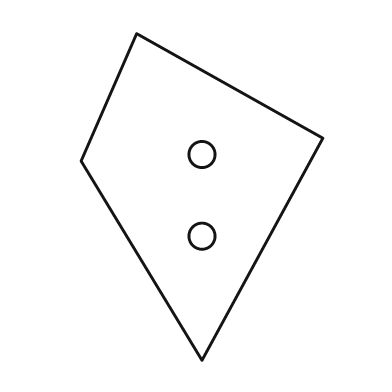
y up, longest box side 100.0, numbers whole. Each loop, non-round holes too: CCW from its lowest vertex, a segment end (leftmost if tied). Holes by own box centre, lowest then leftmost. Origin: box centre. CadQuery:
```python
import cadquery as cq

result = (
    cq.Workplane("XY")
    .moveTo(0.0, -50.0)
    .lineTo(37.0, 18.0)
    .lineTo(-20.0, 50.0)
    .lineTo(-37.0, 11.0)
    .close()
    .moveTo(0.0, -12.0)
    .circle(4.0)
    .moveTo(0.0, 13.0)
    .circle(4.0)
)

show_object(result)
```